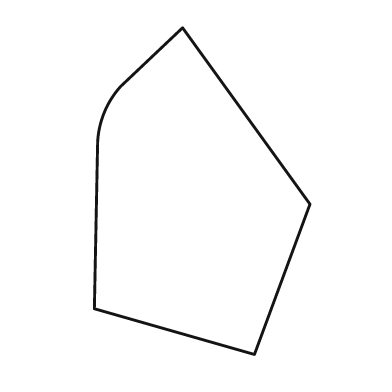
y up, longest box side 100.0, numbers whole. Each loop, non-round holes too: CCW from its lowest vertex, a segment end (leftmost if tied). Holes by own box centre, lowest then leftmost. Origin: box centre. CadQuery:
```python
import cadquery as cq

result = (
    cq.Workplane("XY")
    .moveTo(16.0, -50.0)
    .lineTo(33.0, -4.0)
    .lineTo(-6.0, 50.0)
    .lineTo(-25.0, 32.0)
    .threePointArc((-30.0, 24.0), (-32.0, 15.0))
    .lineTo(-33.0, -36.0)
    .close()
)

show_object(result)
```